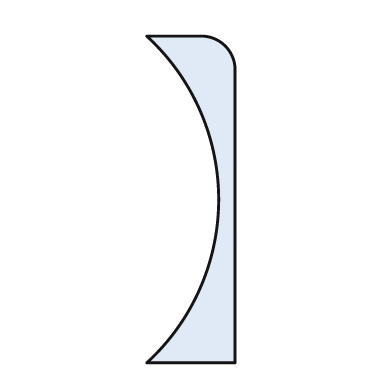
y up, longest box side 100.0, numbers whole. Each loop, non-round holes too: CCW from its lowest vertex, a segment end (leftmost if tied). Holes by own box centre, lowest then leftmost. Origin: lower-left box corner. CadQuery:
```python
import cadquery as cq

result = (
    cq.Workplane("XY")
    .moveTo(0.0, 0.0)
    .lineTo(27.0, 0.0)
    .lineTo(27.0, 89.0)
    .threePointArc((24.0, 97.0), (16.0, 100.0))
    .lineTo(0.0, 100.0)
    .threePointArc((22.0, 50.0), (0.0, 0.0))
    .close()
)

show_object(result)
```